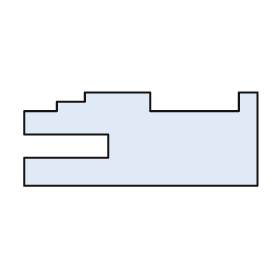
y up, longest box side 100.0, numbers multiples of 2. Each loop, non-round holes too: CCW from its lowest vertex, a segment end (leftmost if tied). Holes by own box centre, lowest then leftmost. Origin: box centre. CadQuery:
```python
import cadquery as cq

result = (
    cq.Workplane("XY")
    .moveTo(-50.0, -20.0)
    .lineTo(50.0, -20.0)
    .lineTo(50.0, 20.0)
    .lineTo(42.0, 20.0)
    .lineTo(42.0, 12.0)
    .lineTo(4.0, 12.0)
    .lineTo(4.0, 20.0)
    .lineTo(-24.0, 20.0)
    .lineTo(-24.0, 16.0)
    .lineTo(-36.0, 16.0)
    .lineTo(-36.0, 12.0)
    .lineTo(-50.0, 12.0)
    .lineTo(-50.0, 2.0)
    .lineTo(-14.0, 2.0)
    .lineTo(-14.0, -8.0)
    .lineTo(-50.0, -8.0)
    .close()
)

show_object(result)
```